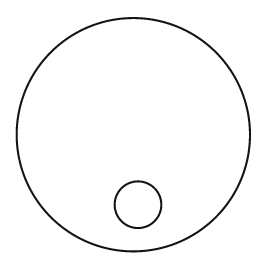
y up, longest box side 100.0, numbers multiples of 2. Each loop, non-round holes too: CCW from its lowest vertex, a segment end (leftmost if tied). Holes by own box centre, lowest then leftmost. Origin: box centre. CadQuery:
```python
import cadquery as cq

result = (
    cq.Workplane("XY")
    .moveTo(0.0, 0.0)
    .circle(50.0)
    .moveTo(2.0, -30.0)
    .circle(10.0)
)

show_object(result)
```